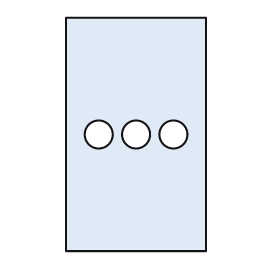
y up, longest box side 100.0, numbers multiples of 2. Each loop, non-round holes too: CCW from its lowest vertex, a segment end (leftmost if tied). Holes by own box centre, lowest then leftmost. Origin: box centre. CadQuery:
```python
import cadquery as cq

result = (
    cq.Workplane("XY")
    .moveTo(-30.0, -50.0)
    .lineTo(30.0, -50.0)
    .lineTo(30.0, 50.0)
    .lineTo(-30.0, 50.0)
    .close()
    .moveTo(-16.0, 0.0)
    .circle(6.0)
    .moveTo(0.0, 0.0)
    .circle(6.0)
    .moveTo(16.0, 0.0)
    .circle(6.0)
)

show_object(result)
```